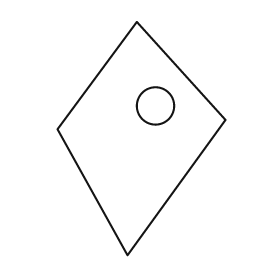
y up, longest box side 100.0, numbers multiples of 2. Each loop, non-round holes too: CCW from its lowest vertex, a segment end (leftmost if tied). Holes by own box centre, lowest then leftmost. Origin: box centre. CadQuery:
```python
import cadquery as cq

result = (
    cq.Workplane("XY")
    .moveTo(-6.0, -50.0)
    .lineTo(36.0, 8.0)
    .lineTo(-2.0, 50.0)
    .lineTo(-36.0, 4.0)
    .close()
    .moveTo(6.0, 14.0)
    .circle(8.0)
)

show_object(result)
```